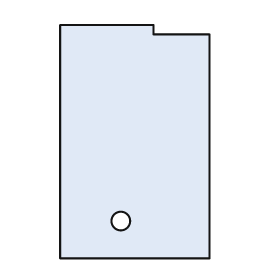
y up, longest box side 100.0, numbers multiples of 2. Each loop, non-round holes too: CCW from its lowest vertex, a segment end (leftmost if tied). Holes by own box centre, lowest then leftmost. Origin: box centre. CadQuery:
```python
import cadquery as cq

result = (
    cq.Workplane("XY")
    .moveTo(-32.0, -50.0)
    .lineTo(32.0, -50.0)
    .lineTo(32.0, 46.0)
    .lineTo(8.0, 46.0)
    .lineTo(8.0, 50.0)
    .lineTo(-32.0, 50.0)
    .close()
    .moveTo(-6.0, -34.0)
    .circle(4.0)
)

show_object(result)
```